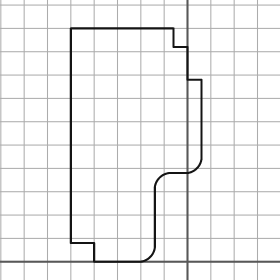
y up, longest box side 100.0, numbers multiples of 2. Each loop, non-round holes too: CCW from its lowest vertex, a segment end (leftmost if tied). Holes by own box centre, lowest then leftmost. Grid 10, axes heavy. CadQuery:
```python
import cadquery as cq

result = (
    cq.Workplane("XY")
    .moveTo(-40.0, 0.0)
    .lineTo(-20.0, 0.0)
    .threePointArc((-16.0, 2.0), (-14.0, 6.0))
    .lineTo(-14.0, 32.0)
    .threePointArc((-12.0, 36.0), (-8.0, 38.0))
    .lineTo(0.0, 38.0)
    .threePointArc((4.0, 40.0), (6.0, 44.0))
    .lineTo(6.0, 78.0)
    .lineTo(0.0, 78.0)
    .lineTo(0.0, 92.0)
    .lineTo(-6.0, 92.0)
    .lineTo(-6.0, 100.0)
    .lineTo(-50.0, 100.0)
    .lineTo(-50.0, 8.0)
    .lineTo(-40.0, 8.0)
    .close()
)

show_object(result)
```